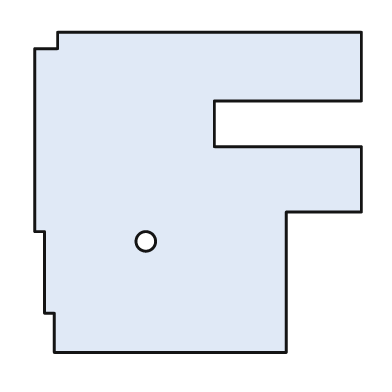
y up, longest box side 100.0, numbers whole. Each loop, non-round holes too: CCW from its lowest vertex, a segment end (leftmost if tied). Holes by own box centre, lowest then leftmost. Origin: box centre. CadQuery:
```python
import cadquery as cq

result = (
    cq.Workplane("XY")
    .moveTo(-44.0, -49.0)
    .lineTo(27.0, -49.0)
    .lineTo(27.0, -6.0)
    .lineTo(50.0, -6.0)
    .lineTo(50.0, 14.0)
    .lineTo(5.0, 14.0)
    .lineTo(5.0, 28.0)
    .lineTo(50.0, 28.0)
    .lineTo(50.0, 49.0)
    .lineTo(-43.0, 49.0)
    .lineTo(-43.0, 44.0)
    .lineTo(-50.0, 44.0)
    .lineTo(-50.0, -12.0)
    .lineTo(-47.0, -12.0)
    .lineTo(-47.0, -37.0)
    .lineTo(-44.0, -37.0)
    .close()
    .moveTo(-16.0, -15.0)
    .circle(3.0)
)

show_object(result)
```